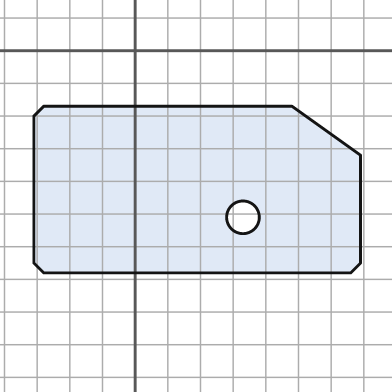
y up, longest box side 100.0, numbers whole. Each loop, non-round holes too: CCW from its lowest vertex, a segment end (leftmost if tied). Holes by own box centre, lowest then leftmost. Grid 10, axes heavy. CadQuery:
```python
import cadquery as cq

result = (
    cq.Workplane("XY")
    .moveTo(-28.0, -68.0)
    .lineTo(66.0, -68.0)
    .lineTo(69.0, -65.0)
    .lineTo(69.0, -32.0)
    .lineTo(48.0, -17.0)
    .lineTo(-28.0, -17.0)
    .lineTo(-31.0, -20.0)
    .lineTo(-31.0, -65.0)
    .close()
    .moveTo(33.0, -51.0)
    .circle(5.0)
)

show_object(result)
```